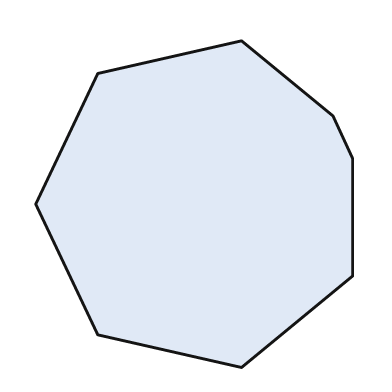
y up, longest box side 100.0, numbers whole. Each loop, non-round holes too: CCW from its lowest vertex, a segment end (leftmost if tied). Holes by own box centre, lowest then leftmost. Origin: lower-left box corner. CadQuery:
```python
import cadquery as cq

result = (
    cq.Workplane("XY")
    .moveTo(63.0, 0.0)
    .lineTo(97.0, 28.0)
    .lineTo(97.0, 64.0)
    .lineTo(91.0, 77.0)
    .lineTo(63.0, 100.0)
    .lineTo(19.0, 90.0)
    .lineTo(0.0, 50.0)
    .lineTo(19.0, 10.0)
    .close()
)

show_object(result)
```